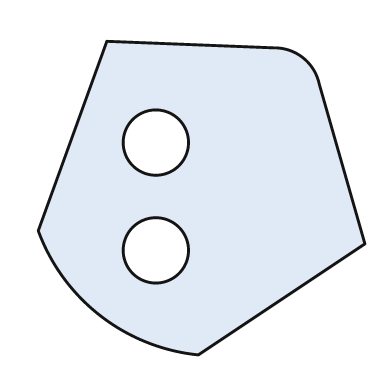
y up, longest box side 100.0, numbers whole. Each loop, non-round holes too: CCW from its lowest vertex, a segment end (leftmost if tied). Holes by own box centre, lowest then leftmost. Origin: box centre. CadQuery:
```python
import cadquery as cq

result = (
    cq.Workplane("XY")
    .moveTo(-1.0, -48.0)
    .lineTo(50.0, -14.0)
    .lineTo(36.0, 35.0)
    .threePointArc((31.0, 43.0), (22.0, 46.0))
    .lineTo(-29.0, 48.0)
    .lineTo(-50.0, -10.0)
    .threePointArc((-31.0, -36.0), (-1.0, -48.0))
    .close()
    .moveTo(-14.0, -16.0)
    .circle(10.0)
    .moveTo(-14.0, 17.0)
    .circle(10.0)
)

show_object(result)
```